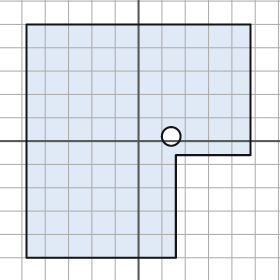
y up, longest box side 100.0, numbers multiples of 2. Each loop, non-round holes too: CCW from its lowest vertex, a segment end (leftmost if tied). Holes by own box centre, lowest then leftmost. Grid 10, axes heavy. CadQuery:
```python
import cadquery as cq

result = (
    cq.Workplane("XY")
    .moveTo(-48.0, -50.0)
    .lineTo(16.0, -50.0)
    .lineTo(16.0, -6.0)
    .lineTo(48.0, -6.0)
    .lineTo(48.0, 50.0)
    .lineTo(-48.0, 50.0)
    .close()
    .moveTo(14.0, 2.0)
    .circle(4.0)
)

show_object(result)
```